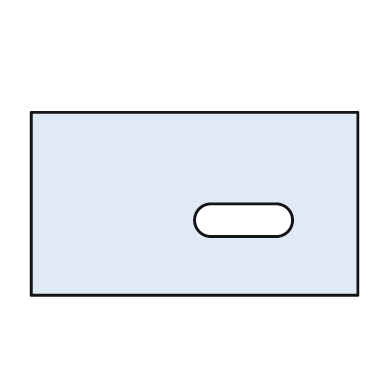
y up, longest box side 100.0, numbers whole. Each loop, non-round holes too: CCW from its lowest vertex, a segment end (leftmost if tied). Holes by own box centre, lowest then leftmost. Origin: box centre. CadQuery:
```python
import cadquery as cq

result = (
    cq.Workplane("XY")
    .moveTo(-50.0, -28.0)
    .lineTo(50.0, -28.0)
    .lineTo(50.0, 28.0)
    .lineTo(-50.0, 28.0)
    .close()
    .moveTo(5.0, -10.0)
    .lineTo(25.0, -10.0)
    .threePointArc((30.0, -5.0), (25.0, 0.0))
    .lineTo(5.0, 0.0)
    .threePointArc((0.0, -5.0), (5.0, -10.0))
    .close()
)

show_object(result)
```